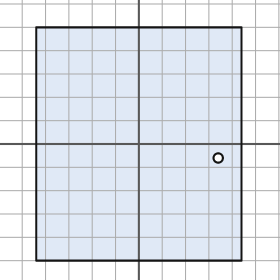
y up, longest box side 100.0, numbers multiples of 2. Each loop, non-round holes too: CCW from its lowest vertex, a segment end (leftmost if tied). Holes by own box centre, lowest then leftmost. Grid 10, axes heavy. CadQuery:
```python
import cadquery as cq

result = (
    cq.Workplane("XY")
    .moveTo(-44.0, -50.0)
    .lineTo(44.0, -50.0)
    .lineTo(44.0, 50.0)
    .lineTo(-44.0, 50.0)
    .close()
    .moveTo(34.0, -6.0)
    .circle(2.0)
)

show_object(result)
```